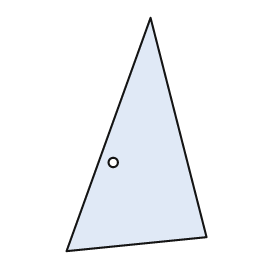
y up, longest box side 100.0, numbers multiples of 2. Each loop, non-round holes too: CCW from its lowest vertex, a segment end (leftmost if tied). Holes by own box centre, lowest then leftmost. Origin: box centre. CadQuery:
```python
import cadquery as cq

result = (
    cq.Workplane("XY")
    .moveTo(-30.0, -50.0)
    .lineTo(30.0, -44.0)
    .lineTo(6.0, 50.0)
    .close()
    .moveTo(-10.0, -12.0)
    .circle(2.0)
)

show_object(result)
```